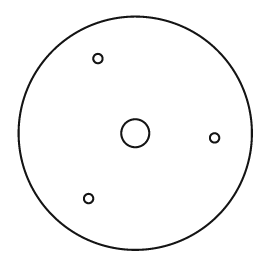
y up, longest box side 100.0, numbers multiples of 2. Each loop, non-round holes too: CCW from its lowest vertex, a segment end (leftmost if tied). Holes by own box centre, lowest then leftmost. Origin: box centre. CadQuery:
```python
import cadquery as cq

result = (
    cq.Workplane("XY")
    .moveTo(0.0, 0.0)
    .circle(50.0)
    .moveTo(-20.0, -28.0)
    .circle(2.0)
    .moveTo(34.0, -2.0)
    .circle(2.0)
    .moveTo(0.0, 0.0)
    .circle(6.0)
    .moveTo(-16.0, 32.0)
    .circle(2.0)
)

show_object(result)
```